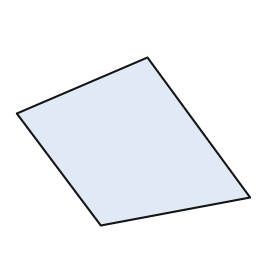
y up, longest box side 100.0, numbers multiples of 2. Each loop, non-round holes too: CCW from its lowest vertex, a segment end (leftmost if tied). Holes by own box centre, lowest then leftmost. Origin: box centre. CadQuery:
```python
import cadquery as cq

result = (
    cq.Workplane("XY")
    .moveTo(-14.0, -36.0)
    .lineTo(50.0, -24.0)
    .lineTo(6.0, 36.0)
    .lineTo(-50.0, 12.0)
    .close()
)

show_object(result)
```